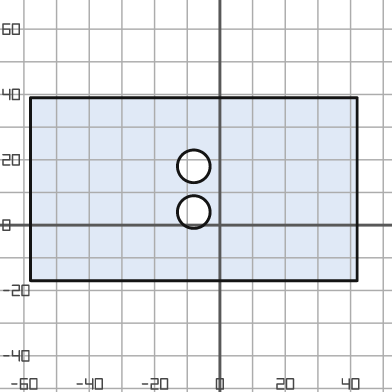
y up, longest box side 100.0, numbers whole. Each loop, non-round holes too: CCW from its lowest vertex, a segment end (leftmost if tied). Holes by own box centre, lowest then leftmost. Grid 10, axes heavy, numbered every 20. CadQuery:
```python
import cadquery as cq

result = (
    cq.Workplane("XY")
    .moveTo(-58.0, -17.0)
    .lineTo(42.0, -17.0)
    .lineTo(42.0, 39.0)
    .lineTo(-58.0, 39.0)
    .close()
    .moveTo(-8.0, 4.0)
    .circle(5.0)
    .moveTo(-8.0, 18.0)
    .circle(5.0)
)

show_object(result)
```